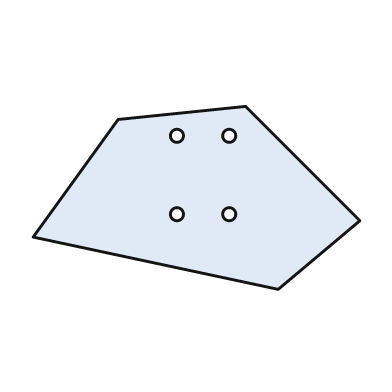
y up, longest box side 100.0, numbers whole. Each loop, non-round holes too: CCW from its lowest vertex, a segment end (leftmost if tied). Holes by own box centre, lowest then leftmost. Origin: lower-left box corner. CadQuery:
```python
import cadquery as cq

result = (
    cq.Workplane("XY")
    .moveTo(75.0, 0.0)
    .lineTo(100.0, 21.0)
    .lineTo(65.0, 56.0)
    .lineTo(26.0, 52.0)
    .lineTo(0.0, 16.0)
    .close()
    .moveTo(44.0, 23.0)
    .circle(2.0)
    .moveTo(60.0, 23.0)
    .circle(2.0)
    .moveTo(44.0, 47.0)
    .circle(2.0)
    .moveTo(60.0, 47.0)
    .circle(2.0)
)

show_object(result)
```